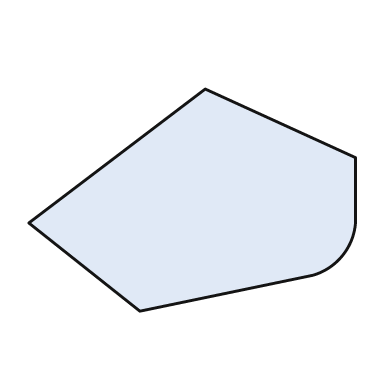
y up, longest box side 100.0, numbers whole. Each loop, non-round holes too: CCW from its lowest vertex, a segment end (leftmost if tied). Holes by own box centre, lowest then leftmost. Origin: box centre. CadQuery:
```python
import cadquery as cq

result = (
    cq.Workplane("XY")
    .moveTo(-16.0, -34.0)
    .lineTo(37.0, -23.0)
    .threePointArc((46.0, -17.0), (50.0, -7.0))
    .lineTo(50.0, 13.0)
    .lineTo(4.0, 34.0)
    .lineTo(-50.0, -7.0)
    .close()
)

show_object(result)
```